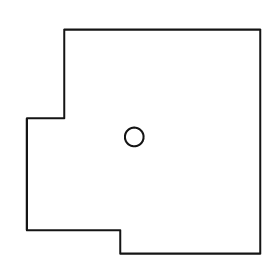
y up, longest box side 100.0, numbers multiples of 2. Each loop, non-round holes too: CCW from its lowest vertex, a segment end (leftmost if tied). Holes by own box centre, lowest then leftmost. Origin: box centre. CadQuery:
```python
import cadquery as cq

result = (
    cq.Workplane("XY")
    .moveTo(-10.0, -48.0)
    .lineTo(50.0, -48.0)
    .lineTo(50.0, 48.0)
    .lineTo(-34.0, 48.0)
    .lineTo(-34.0, 10.0)
    .lineTo(-50.0, 10.0)
    .lineTo(-50.0, -38.0)
    .lineTo(-10.0, -38.0)
    .close()
    .moveTo(-4.0, 2.0)
    .circle(4.0)
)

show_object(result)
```